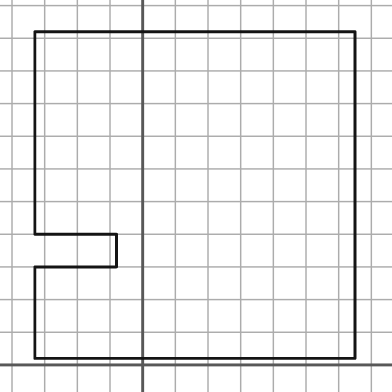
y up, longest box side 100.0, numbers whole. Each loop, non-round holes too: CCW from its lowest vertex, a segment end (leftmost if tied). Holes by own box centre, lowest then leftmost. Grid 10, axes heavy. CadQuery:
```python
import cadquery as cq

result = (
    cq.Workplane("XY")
    .moveTo(-33.0, 2.0)
    .lineTo(65.0, 2.0)
    .lineTo(65.0, 102.0)
    .lineTo(-33.0, 102.0)
    .lineTo(-33.0, 40.0)
    .lineTo(-8.0, 40.0)
    .lineTo(-8.0, 30.0)
    .lineTo(-33.0, 30.0)
    .close()
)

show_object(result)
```